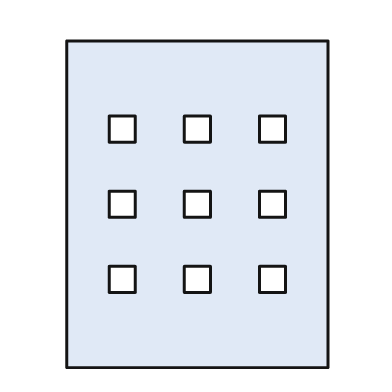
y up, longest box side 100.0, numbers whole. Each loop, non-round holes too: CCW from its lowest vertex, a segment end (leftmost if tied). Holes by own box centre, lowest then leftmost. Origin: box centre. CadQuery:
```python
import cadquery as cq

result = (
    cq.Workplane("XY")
    .moveTo(-40.0, -50.0)
    .lineTo(40.0, -50.0)
    .lineTo(40.0, 50.0)
    .lineTo(-40.0, 50.0)
    .close()
    .moveTo(-27.0, -27.0)
    .lineTo(-19.0, -27.0)
    .lineTo(-19.0, -19.0)
    .lineTo(-27.0, -19.0)
    .close()
    .moveTo(-4.0, -27.0)
    .lineTo(4.0, -27.0)
    .lineTo(4.0, -19.0)
    .lineTo(-4.0, -19.0)
    .close()
    .moveTo(19.0, -27.0)
    .lineTo(27.0, -27.0)
    .lineTo(27.0, -19.0)
    .lineTo(19.0, -19.0)
    .close()
    .moveTo(-27.0, -4.0)
    .lineTo(-19.0, -4.0)
    .lineTo(-19.0, 4.0)
    .lineTo(-27.0, 4.0)
    .close()
    .moveTo(-4.0, -4.0)
    .lineTo(4.0, -4.0)
    .lineTo(4.0, 4.0)
    .lineTo(-4.0, 4.0)
    .close()
    .moveTo(19.0, -4.0)
    .lineTo(27.0, -4.0)
    .lineTo(27.0, 4.0)
    .lineTo(19.0, 4.0)
    .close()
    .moveTo(-27.0, 19.0)
    .lineTo(-19.0, 19.0)
    .lineTo(-19.0, 27.0)
    .lineTo(-27.0, 27.0)
    .close()
    .moveTo(-4.0, 19.0)
    .lineTo(4.0, 19.0)
    .lineTo(4.0, 27.0)
    .lineTo(-4.0, 27.0)
    .close()
    .moveTo(19.0, 19.0)
    .lineTo(27.0, 19.0)
    .lineTo(27.0, 27.0)
    .lineTo(19.0, 27.0)
    .close()
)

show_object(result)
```